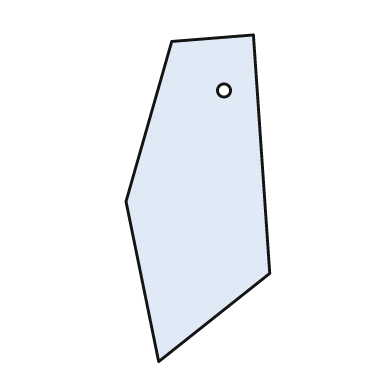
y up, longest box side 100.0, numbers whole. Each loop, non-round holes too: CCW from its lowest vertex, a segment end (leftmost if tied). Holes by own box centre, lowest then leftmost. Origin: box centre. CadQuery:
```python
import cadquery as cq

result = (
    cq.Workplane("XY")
    .moveTo(-12.0, -50.0)
    .lineTo(22.0, -23.0)
    .lineTo(17.0, 50.0)
    .lineTo(-8.0, 48.0)
    .lineTo(-22.0, -1.0)
    .close()
    .moveTo(8.0, 33.0)
    .circle(2.0)
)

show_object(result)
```